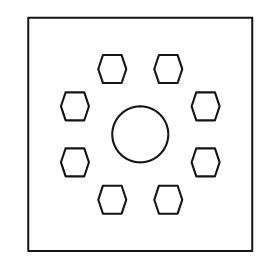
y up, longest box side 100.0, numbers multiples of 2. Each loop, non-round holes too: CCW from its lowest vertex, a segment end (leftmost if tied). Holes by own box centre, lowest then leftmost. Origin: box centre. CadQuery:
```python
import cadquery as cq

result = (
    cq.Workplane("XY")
    .moveTo(-48.0, -50.0)
    .lineTo(48.0, -50.0)
    .lineTo(48.0, 50.0)
    .lineTo(-48.0, 50.0)
    .close()
    .moveTo(-16.0, -34.0)
    .lineTo(-8.0, -34.0)
    .lineTo(-6.0, -28.0)
    .lineTo(-8.0, -22.0)
    .lineTo(-16.0, -22.0)
    .lineTo(-18.0, -28.0)
    .close()
    .moveTo(8.0, -34.0)
    .lineTo(16.0, -34.0)
    .lineTo(18.0, -28.0)
    .lineTo(16.0, -22.0)
    .lineTo(8.0, -22.0)
    .lineTo(6.0, -28.0)
    .close()
    .moveTo(-32.0, -18.0)
    .lineTo(-24.0, -18.0)
    .lineTo(-22.0, -12.0)
    .lineTo(-24.0, -6.0)
    .lineTo(-32.0, -6.0)
    .lineTo(-34.0, -12.0)
    .close()
    .moveTo(24.0, -18.0)
    .lineTo(32.0, -18.0)
    .lineTo(34.0, -12.0)
    .lineTo(32.0, -6.0)
    .lineTo(24.0, -6.0)
    .lineTo(22.0, -12.0)
    .close()
    .moveTo(0.0, 0.0)
    .circle(12.0)
    .moveTo(-32.0, 6.0)
    .lineTo(-24.0, 6.0)
    .lineTo(-22.0, 12.0)
    .lineTo(-24.0, 18.0)
    .lineTo(-32.0, 18.0)
    .lineTo(-34.0, 12.0)
    .close()
    .moveTo(24.0, 6.0)
    .lineTo(32.0, 6.0)
    .lineTo(34.0, 12.0)
    .lineTo(32.0, 18.0)
    .lineTo(24.0, 18.0)
    .lineTo(22.0, 12.0)
    .close()
    .moveTo(-16.0, 22.0)
    .lineTo(-8.0, 22.0)
    .lineTo(-6.0, 28.0)
    .lineTo(-8.0, 34.0)
    .lineTo(-16.0, 34.0)
    .lineTo(-18.0, 28.0)
    .close()
    .moveTo(8.0, 22.0)
    .lineTo(16.0, 22.0)
    .lineTo(18.0, 28.0)
    .lineTo(16.0, 34.0)
    .lineTo(8.0, 34.0)
    .lineTo(6.0, 28.0)
    .close()
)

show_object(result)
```